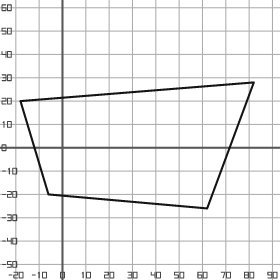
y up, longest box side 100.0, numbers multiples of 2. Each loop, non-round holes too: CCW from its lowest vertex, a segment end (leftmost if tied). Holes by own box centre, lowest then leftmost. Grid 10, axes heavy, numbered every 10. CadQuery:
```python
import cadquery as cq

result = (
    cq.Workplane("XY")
    .moveTo(62.0, -26.0)
    .lineTo(82.0, 28.0)
    .lineTo(-18.0, 20.0)
    .lineTo(-6.0, -20.0)
    .close()
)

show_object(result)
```